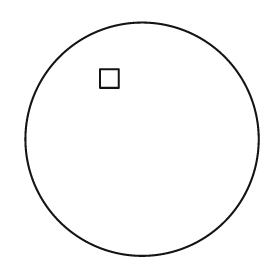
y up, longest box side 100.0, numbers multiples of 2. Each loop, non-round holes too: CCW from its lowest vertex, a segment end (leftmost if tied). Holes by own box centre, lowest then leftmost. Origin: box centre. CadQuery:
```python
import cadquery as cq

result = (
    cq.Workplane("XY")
    .moveTo(0.0, 0.0)
    .circle(50.0)
    .moveTo(-18.0, 22.0)
    .lineTo(-10.0, 22.0)
    .lineTo(-10.0, 30.0)
    .lineTo(-18.0, 30.0)
    .close()
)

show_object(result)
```